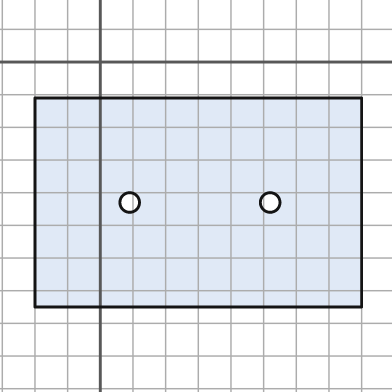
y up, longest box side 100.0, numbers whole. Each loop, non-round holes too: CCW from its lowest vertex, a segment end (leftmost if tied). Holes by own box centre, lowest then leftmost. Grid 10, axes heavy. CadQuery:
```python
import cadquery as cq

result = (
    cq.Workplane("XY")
    .moveTo(-20.0, -75.0)
    .lineTo(80.0, -75.0)
    .lineTo(80.0, -11.0)
    .lineTo(-20.0, -11.0)
    .close()
    .moveTo(9.0, -43.0)
    .circle(3.0)
    .moveTo(52.0, -43.0)
    .circle(3.0)
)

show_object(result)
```